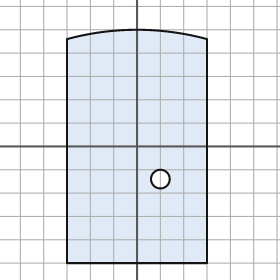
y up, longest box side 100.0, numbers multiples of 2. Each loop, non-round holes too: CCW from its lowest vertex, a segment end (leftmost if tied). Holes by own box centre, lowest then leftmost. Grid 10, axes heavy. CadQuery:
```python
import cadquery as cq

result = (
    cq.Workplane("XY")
    .moveTo(-30.0, -50.0)
    .lineTo(30.0, -50.0)
    .lineTo(30.0, 46.0)
    .threePointArc((0.0, 50.0), (-30.0, 46.0))
    .close()
    .moveTo(10.0, -14.0)
    .circle(4.0)
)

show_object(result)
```